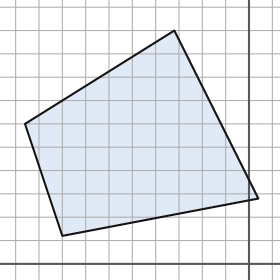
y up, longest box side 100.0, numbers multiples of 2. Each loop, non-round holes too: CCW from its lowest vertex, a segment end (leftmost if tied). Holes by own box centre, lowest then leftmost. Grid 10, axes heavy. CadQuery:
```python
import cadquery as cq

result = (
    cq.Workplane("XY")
    .moveTo(-80.0, 12.0)
    .lineTo(4.0, 28.0)
    .lineTo(-32.0, 100.0)
    .lineTo(-96.0, 60.0)
    .close()
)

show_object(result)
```